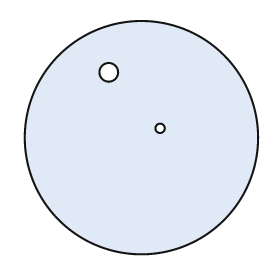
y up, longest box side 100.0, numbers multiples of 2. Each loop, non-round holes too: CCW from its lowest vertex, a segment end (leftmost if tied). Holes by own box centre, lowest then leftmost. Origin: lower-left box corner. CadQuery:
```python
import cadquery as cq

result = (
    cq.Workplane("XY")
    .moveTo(50.0, 50.0)
    .circle(50.0)
    .moveTo(58.0, 54.0)
    .circle(2.0)
    .moveTo(36.0, 78.0)
    .circle(4.0)
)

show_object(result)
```